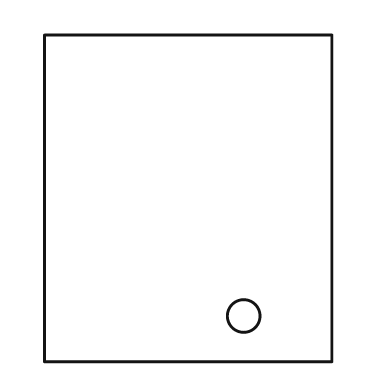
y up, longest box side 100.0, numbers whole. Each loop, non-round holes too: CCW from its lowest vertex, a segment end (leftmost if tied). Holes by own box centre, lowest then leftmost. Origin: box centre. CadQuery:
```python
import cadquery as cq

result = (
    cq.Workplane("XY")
    .moveTo(-44.0, -50.0)
    .lineTo(44.0, -50.0)
    .lineTo(44.0, 50.0)
    .lineTo(-44.0, 50.0)
    .close()
    .moveTo(17.0, -36.0)
    .circle(5.0)
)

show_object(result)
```